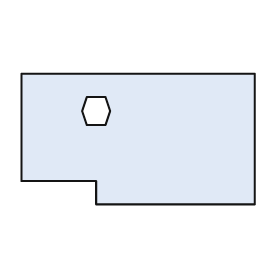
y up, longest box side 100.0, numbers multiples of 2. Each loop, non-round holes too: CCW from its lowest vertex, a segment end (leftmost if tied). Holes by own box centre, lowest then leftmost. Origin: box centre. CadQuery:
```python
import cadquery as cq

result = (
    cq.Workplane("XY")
    .moveTo(-18.0, -28.0)
    .lineTo(50.0, -28.0)
    .lineTo(50.0, 28.0)
    .lineTo(-50.0, 28.0)
    .lineTo(-50.0, -18.0)
    .lineTo(-18.0, -18.0)
    .close()
    .moveTo(-22.0, 6.0)
    .lineTo(-14.0, 6.0)
    .lineTo(-12.0, 12.0)
    .lineTo(-14.0, 18.0)
    .lineTo(-22.0, 18.0)
    .lineTo(-24.0, 12.0)
    .close()
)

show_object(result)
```